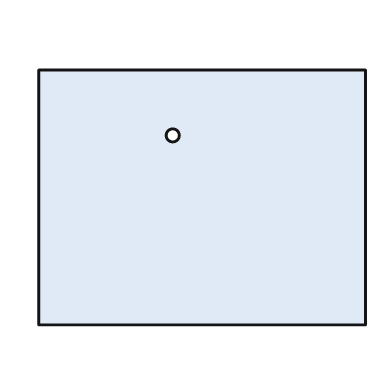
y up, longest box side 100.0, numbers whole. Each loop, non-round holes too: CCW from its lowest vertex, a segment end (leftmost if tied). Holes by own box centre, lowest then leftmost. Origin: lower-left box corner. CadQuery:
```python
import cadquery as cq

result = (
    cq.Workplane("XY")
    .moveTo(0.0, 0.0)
    .lineTo(100.0, 0.0)
    .lineTo(100.0, 78.0)
    .lineTo(0.0, 78.0)
    .close()
    .moveTo(41.0, 58.0)
    .circle(2.0)
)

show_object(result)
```